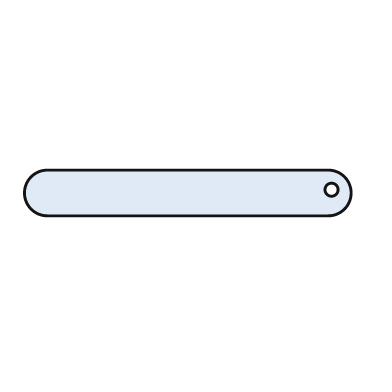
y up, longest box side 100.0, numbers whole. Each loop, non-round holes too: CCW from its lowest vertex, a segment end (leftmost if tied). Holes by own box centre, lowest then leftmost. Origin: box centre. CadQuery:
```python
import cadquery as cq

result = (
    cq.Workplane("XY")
    .moveTo(-43.0, -7.0)
    .lineTo(43.0, -7.0)
    .threePointArc((50.0, 0.0), (43.0, 7.0))
    .lineTo(-43.0, 7.0)
    .threePointArc((-50.0, 0.0), (-43.0, -7.0))
    .close()
    .moveTo(44.0, 1.0)
    .circle(2.0)
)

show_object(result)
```